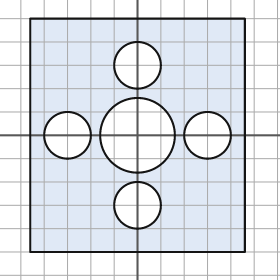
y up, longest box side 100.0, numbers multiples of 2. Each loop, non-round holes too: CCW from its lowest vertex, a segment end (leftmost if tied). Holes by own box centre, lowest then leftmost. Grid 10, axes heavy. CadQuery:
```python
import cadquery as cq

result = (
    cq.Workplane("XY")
    .moveTo(-46.0, -50.0)
    .lineTo(46.0, -50.0)
    .lineTo(46.0, 50.0)
    .lineTo(-46.0, 50.0)
    .close()
    .moveTo(0.0, -30.0)
    .circle(10.0)
    .moveTo(-30.0, 0.0)
    .circle(10.0)
    .moveTo(0.0, 0.0)
    .circle(16.0)
    .moveTo(30.0, 0.0)
    .circle(10.0)
    .moveTo(0.0, 30.0)
    .circle(10.0)
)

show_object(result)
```